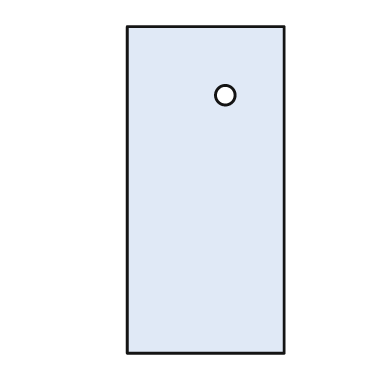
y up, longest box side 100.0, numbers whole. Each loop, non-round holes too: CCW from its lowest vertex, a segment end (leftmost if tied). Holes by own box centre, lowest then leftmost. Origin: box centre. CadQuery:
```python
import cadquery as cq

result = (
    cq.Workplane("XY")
    .moveTo(-24.0, -50.0)
    .lineTo(24.0, -50.0)
    .lineTo(24.0, 50.0)
    .lineTo(-24.0, 50.0)
    .close()
    .moveTo(6.0, 29.0)
    .circle(3.0)
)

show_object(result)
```